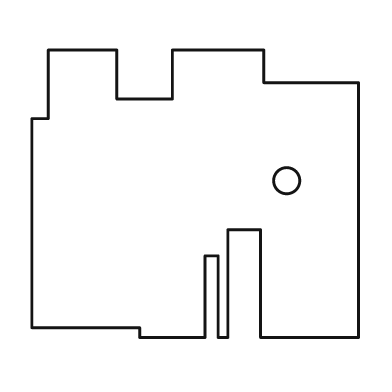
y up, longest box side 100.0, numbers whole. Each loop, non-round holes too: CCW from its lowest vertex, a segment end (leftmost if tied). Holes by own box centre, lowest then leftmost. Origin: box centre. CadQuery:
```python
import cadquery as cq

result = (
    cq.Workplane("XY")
    .moveTo(-17.0, -44.0)
    .lineTo(3.0, -44.0)
    .lineTo(3.0, -19.0)
    .lineTo(7.0, -19.0)
    .lineTo(7.0, -44.0)
    .lineTo(10.0, -44.0)
    .lineTo(10.0, -11.0)
    .lineTo(20.0, -11.0)
    .lineTo(20.0, -44.0)
    .lineTo(50.0, -44.0)
    .lineTo(50.0, 34.0)
    .lineTo(21.0, 34.0)
    .lineTo(21.0, 44.0)
    .lineTo(-7.0, 44.0)
    .lineTo(-7.0, 29.0)
    .lineTo(-24.0, 29.0)
    .lineTo(-24.0, 44.0)
    .lineTo(-45.0, 44.0)
    .lineTo(-45.0, 23.0)
    .lineTo(-50.0, 23.0)
    .lineTo(-50.0, -41.0)
    .lineTo(-17.0, -41.0)
    .close()
    .moveTo(28.0, 4.0)
    .circle(4.0)
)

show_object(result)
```